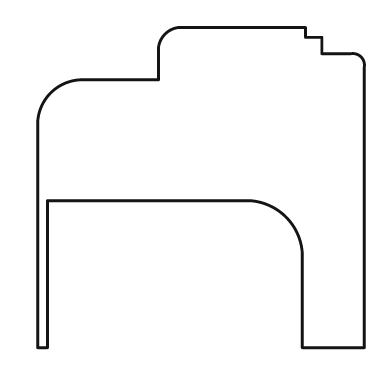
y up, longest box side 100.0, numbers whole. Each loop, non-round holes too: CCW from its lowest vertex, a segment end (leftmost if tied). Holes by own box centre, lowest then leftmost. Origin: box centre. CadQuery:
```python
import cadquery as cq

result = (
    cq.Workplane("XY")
    .moveTo(-50.0, -49.0)
    .lineTo(-47.0, -49.0)
    .lineTo(-47.0, -4.0)
    .lineTo(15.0, -4.0)
    .threePointArc((26.0, -9.0), (31.0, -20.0))
    .lineTo(31.0, -49.0)
    .lineTo(50.0, -49.0)
    .lineTo(50.0, 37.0)
    .threePointArc((49.0, 40.0), (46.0, 41.0))
    .lineTo(37.0, 41.0)
    .lineTo(37.0, 46.0)
    .lineTo(32.0, 46.0)
    .lineTo(32.0, 49.0)
    .lineTo(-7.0, 49.0)
    .threePointArc((-11.0, 47.0), (-13.0, 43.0))
    .lineTo(-13.0, 33.0)
    .lineTo(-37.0, 33.0)
    .threePointArc((-46.0, 29.0), (-50.0, 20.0))
    .close()
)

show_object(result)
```